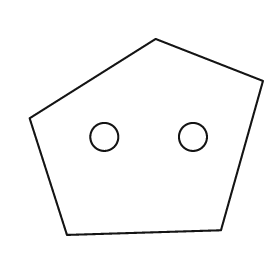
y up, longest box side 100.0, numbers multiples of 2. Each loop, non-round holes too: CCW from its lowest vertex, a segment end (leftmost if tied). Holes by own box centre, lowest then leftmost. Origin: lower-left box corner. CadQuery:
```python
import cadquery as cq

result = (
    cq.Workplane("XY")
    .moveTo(16.0, 0.0)
    .lineTo(82.0, 2.0)
    .lineTo(100.0, 66.0)
    .lineTo(54.0, 84.0)
    .lineTo(0.0, 50.0)
    .close()
    .moveTo(32.0, 42.0)
    .circle(6.0)
    .moveTo(70.0, 42.0)
    .circle(6.0)
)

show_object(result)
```